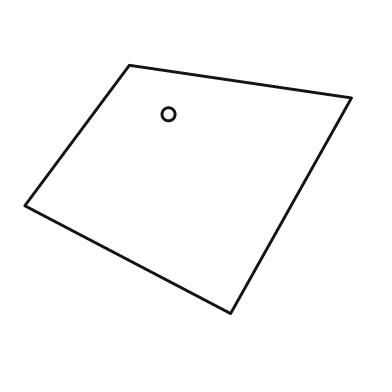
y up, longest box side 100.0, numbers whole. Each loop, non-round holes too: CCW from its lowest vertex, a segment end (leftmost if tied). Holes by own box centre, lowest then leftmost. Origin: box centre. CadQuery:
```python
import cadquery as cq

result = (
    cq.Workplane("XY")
    .moveTo(13.0, -38.0)
    .lineTo(50.0, 28.0)
    .lineTo(-18.0, 38.0)
    .lineTo(-50.0, -5.0)
    .close()
    .moveTo(-6.0, 23.0)
    .circle(2.0)
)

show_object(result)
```